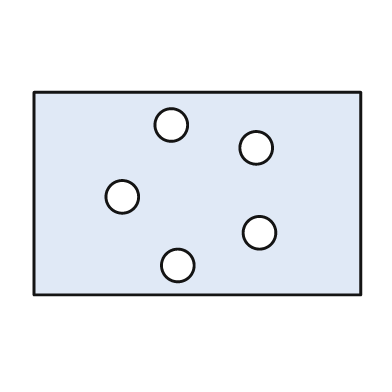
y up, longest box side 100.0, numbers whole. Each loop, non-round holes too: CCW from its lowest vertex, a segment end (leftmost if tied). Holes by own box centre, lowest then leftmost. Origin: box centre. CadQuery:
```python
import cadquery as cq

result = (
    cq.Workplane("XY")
    .moveTo(-50.0, -31.0)
    .lineTo(50.0, -31.0)
    .lineTo(50.0, 31.0)
    .lineTo(-50.0, 31.0)
    .close()
    .moveTo(-6.0, -22.0)
    .circle(5.0)
    .moveTo(19.0, -12.0)
    .circle(5.0)
    .moveTo(-23.0, -1.0)
    .circle(5.0)
    .moveTo(18.0, 14.0)
    .circle(5.0)
    .moveTo(-8.0, 21.0)
    .circle(5.0)
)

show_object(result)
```